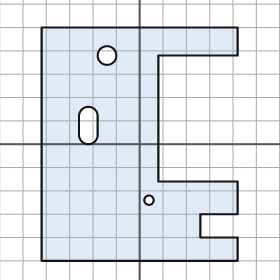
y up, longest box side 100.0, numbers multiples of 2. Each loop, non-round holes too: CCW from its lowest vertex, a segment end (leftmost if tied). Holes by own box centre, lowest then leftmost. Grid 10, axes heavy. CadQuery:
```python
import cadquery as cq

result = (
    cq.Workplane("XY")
    .moveTo(-42.0, -50.0)
    .lineTo(42.0, -50.0)
    .lineTo(42.0, -40.0)
    .lineTo(26.0, -40.0)
    .lineTo(26.0, -30.0)
    .lineTo(42.0, -30.0)
    .lineTo(42.0, -16.0)
    .lineTo(8.0, -16.0)
    .lineTo(8.0, 38.0)
    .lineTo(42.0, 38.0)
    .lineTo(42.0, 50.0)
    .lineTo(-42.0, 50.0)
    .close()
    .moveTo(4.0, -24.0)
    .circle(2.0)
    .moveTo(-26.0, 4.0)
    .threePointArc((-22.0, 0.0), (-18.0, 4.0))
    .lineTo(-18.0, 12.0)
    .threePointArc((-22.0, 16.0), (-26.0, 12.0))
    .close()
    .moveTo(-14.0, 38.0)
    .circle(4.0)
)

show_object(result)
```